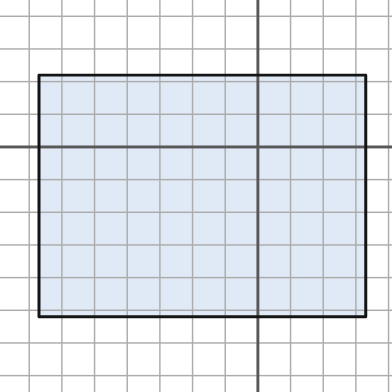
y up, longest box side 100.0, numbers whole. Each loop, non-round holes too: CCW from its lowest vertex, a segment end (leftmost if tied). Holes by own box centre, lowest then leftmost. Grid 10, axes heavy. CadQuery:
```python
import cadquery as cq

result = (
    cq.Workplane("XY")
    .moveTo(-67.0, -52.0)
    .lineTo(33.0, -52.0)
    .lineTo(33.0, 22.0)
    .lineTo(-67.0, 22.0)
    .close()
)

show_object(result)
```